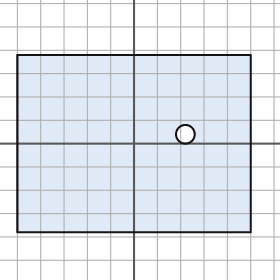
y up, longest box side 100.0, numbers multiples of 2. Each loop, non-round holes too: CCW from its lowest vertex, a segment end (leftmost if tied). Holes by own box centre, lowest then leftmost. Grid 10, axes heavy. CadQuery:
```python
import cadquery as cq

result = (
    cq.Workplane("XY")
    .moveTo(-50.0, -38.0)
    .lineTo(50.0, -38.0)
    .lineTo(50.0, 38.0)
    .lineTo(-50.0, 38.0)
    .close()
    .moveTo(22.0, 4.0)
    .circle(4.0)
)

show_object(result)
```